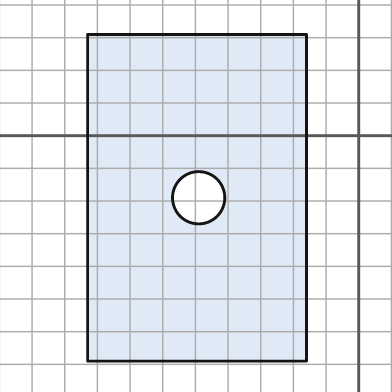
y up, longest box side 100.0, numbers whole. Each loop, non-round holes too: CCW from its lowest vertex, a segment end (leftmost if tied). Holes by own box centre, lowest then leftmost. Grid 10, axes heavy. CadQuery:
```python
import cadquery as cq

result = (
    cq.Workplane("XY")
    .moveTo(-83.0, -69.0)
    .lineTo(-16.0, -69.0)
    .lineTo(-16.0, 31.0)
    .lineTo(-83.0, 31.0)
    .close()
    .moveTo(-49.0, -19.0)
    .circle(8.0)
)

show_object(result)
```